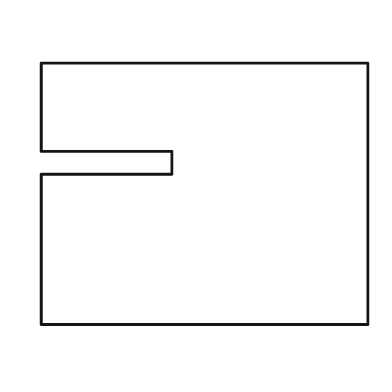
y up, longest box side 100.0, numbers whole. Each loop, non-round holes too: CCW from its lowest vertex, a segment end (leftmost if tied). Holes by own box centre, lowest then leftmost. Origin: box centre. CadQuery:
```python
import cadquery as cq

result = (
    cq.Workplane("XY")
    .moveTo(-50.0, -40.0)
    .lineTo(50.0, -40.0)
    .lineTo(50.0, 40.0)
    .lineTo(-50.0, 40.0)
    .lineTo(-50.0, 13.0)
    .lineTo(-10.0, 13.0)
    .lineTo(-10.0, 6.0)
    .lineTo(-50.0, 6.0)
    .close()
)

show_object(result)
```